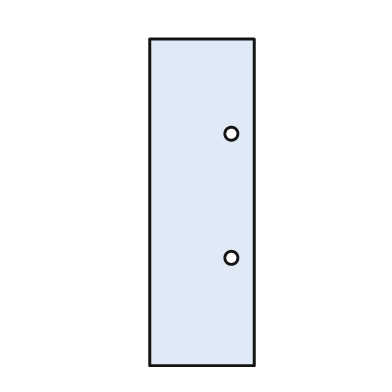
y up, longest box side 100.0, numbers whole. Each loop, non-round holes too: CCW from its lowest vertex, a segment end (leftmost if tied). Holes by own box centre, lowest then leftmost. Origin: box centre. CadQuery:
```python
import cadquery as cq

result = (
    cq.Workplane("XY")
    .moveTo(-16.0, -50.0)
    .lineTo(16.0, -50.0)
    .lineTo(16.0, 50.0)
    .lineTo(-16.0, 50.0)
    .close()
    .moveTo(9.0, -17.0)
    .circle(2.0)
    .moveTo(9.0, 21.0)
    .circle(2.0)
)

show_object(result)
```